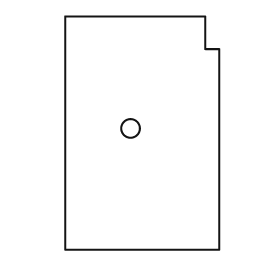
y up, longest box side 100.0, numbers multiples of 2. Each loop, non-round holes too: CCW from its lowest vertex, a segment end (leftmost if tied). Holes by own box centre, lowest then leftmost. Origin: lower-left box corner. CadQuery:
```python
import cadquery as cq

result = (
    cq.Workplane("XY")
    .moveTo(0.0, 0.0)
    .lineTo(66.0, 0.0)
    .lineTo(66.0, 86.0)
    .lineTo(60.0, 86.0)
    .lineTo(60.0, 100.0)
    .lineTo(0.0, 100.0)
    .close()
    .moveTo(28.0, 52.0)
    .circle(4.0)
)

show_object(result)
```